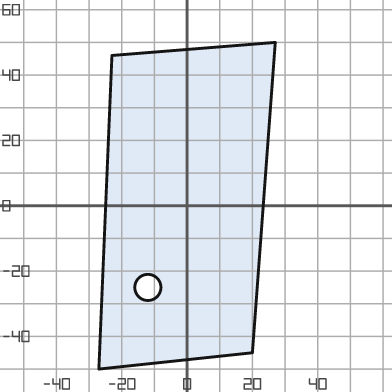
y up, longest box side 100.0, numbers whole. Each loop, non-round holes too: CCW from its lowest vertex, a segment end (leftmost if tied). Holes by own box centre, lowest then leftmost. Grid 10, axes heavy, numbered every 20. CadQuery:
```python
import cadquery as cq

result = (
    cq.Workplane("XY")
    .moveTo(-27.0, -50.0)
    .lineTo(20.0, -45.0)
    .lineTo(27.0, 50.0)
    .lineTo(-23.0, 46.0)
    .close()
    .moveTo(-12.0, -25.0)
    .circle(4.0)
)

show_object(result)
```